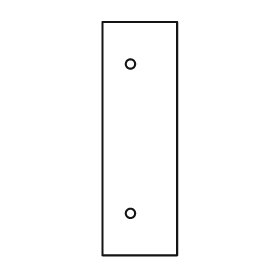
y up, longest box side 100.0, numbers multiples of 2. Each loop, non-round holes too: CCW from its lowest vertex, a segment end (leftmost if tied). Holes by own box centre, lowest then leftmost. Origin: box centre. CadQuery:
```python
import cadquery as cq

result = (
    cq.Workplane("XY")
    .moveTo(-16.0, -50.0)
    .lineTo(16.0, -50.0)
    .lineTo(16.0, 50.0)
    .lineTo(-16.0, 50.0)
    .close()
    .moveTo(-4.0, -32.0)
    .circle(2.0)
    .moveTo(-4.0, 32.0)
    .circle(2.0)
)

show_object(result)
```